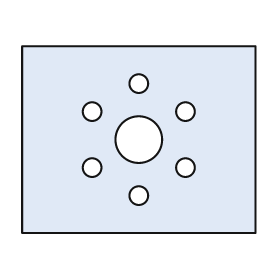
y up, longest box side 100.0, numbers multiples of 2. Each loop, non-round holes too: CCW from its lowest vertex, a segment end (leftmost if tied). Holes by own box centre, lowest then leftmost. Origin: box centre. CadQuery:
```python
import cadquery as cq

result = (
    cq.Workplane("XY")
    .moveTo(-50.0, -40.0)
    .lineTo(50.0, -40.0)
    .lineTo(50.0, 40.0)
    .lineTo(-50.0, 40.0)
    .close()
    .moveTo(0.0, -24.0)
    .circle(4.0)
    .moveTo(-20.0, -12.0)
    .circle(4.0)
    .moveTo(20.0, -12.0)
    .circle(4.0)
    .moveTo(0.0, 0.0)
    .circle(10.0)
    .moveTo(-20.0, 12.0)
    .circle(4.0)
    .moveTo(20.0, 12.0)
    .circle(4.0)
    .moveTo(0.0, 24.0)
    .circle(4.0)
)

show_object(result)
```